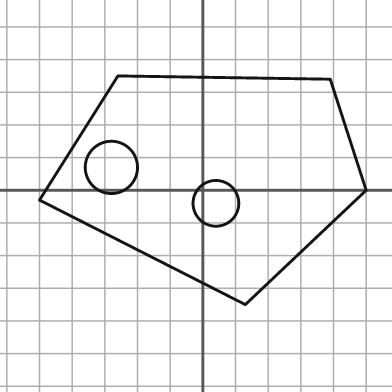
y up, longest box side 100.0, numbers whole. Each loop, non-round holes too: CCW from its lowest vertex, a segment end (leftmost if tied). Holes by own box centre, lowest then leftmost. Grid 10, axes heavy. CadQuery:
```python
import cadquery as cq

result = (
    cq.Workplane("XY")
    .moveTo(13.0, -35.0)
    .lineTo(50.0, 0.0)
    .lineTo(39.0, 34.0)
    .lineTo(-26.0, 35.0)
    .lineTo(-50.0, -3.0)
    .close()
    .moveTo(4.0, -4.0)
    .circle(7.0)
    .moveTo(-28.0, 7.0)
    .circle(8.0)
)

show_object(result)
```